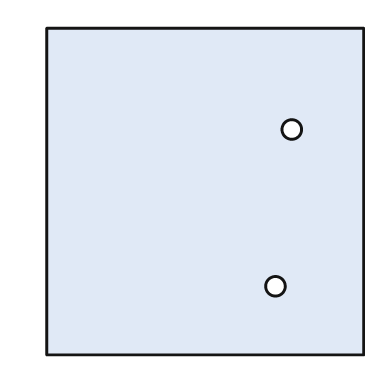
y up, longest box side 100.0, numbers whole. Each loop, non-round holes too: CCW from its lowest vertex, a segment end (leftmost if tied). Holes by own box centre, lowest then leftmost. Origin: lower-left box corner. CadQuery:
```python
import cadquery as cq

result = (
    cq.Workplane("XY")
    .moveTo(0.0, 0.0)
    .lineTo(97.0, 0.0)
    .lineTo(97.0, 100.0)
    .lineTo(0.0, 100.0)
    .close()
    .moveTo(70.0, 21.0)
    .circle(3.0)
    .moveTo(75.0, 69.0)
    .circle(3.0)
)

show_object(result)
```